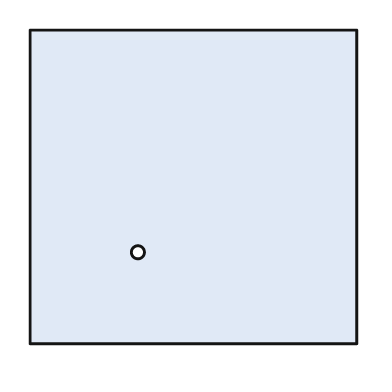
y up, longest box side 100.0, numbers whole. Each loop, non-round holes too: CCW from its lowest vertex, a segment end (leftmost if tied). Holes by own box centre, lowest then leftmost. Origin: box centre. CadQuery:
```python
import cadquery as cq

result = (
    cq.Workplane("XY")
    .moveTo(-50.0, -48.0)
    .lineTo(50.0, -48.0)
    .lineTo(50.0, 48.0)
    .lineTo(-50.0, 48.0)
    .close()
    .moveTo(-17.0, -20.0)
    .circle(2.0)
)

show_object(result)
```